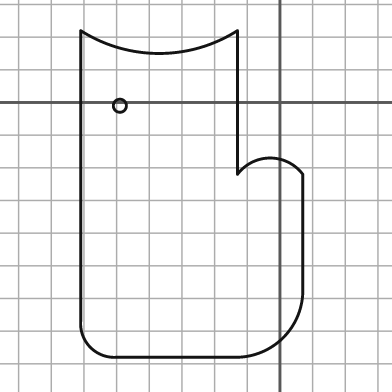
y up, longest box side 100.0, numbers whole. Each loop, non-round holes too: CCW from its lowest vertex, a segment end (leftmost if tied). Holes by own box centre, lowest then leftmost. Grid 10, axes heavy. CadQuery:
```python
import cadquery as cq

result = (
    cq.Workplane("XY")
    .moveTo(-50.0, -78.0)
    .lineTo(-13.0, -78.0)
    .threePointArc((1.0, -72.0), (7.0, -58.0))
    .lineTo(7.0, -22.0)
    .threePointArc((-3.0, -17.0), (-13.0, -22.0))
    .lineTo(-13.0, 22.0)
    .threePointArc((-37.0, 15.0), (-61.0, 22.0))
    .lineTo(-61.0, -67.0)
    .threePointArc((-58.0, -75.0), (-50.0, -78.0))
    .close()
    .moveTo(-49.0, -1.0)
    .circle(2.0)
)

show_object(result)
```